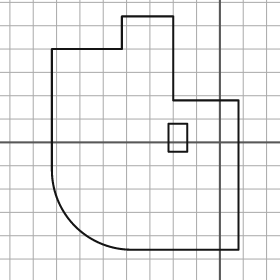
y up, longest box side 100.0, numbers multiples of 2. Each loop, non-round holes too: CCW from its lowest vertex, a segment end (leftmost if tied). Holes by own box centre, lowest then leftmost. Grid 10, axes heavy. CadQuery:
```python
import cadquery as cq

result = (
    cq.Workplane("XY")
    .moveTo(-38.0, -46.0)
    .lineTo(8.0, -46.0)
    .lineTo(8.0, 18.0)
    .lineTo(-20.0, 18.0)
    .lineTo(-20.0, 54.0)
    .lineTo(-42.0, 54.0)
    .lineTo(-42.0, 40.0)
    .lineTo(-72.0, 40.0)
    .lineTo(-72.0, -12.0)
    .threePointArc((-62.0, -36.0), (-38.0, -46.0))
    .close()
    .moveTo(-22.0, -4.0)
    .lineTo(-14.0, -4.0)
    .lineTo(-14.0, 8.0)
    .lineTo(-22.0, 8.0)
    .close()
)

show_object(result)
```